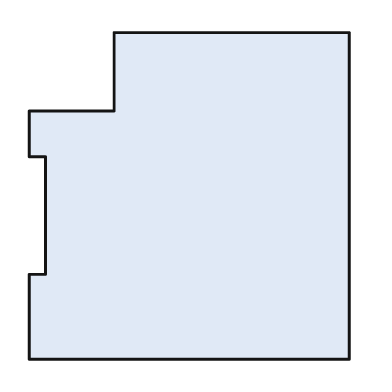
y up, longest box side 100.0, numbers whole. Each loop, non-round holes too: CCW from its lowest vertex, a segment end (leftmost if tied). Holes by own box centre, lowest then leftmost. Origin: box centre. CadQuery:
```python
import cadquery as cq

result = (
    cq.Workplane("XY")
    .moveTo(-49.0, -50.0)
    .lineTo(49.0, -50.0)
    .lineTo(49.0, 50.0)
    .lineTo(-23.0, 50.0)
    .lineTo(-23.0, 26.0)
    .lineTo(-49.0, 26.0)
    .lineTo(-49.0, 12.0)
    .lineTo(-44.0, 12.0)
    .lineTo(-44.0, -24.0)
    .lineTo(-49.0, -24.0)
    .close()
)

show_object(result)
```